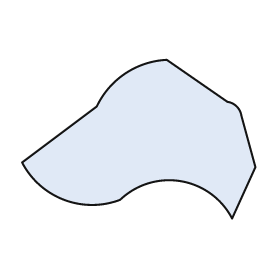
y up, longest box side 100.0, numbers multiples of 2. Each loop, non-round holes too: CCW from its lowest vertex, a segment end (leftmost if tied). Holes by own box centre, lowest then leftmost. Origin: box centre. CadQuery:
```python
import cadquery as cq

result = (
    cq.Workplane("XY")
    .moveTo(40.0, -34.0)
    .lineTo(50.0, -12.0)
    .lineTo(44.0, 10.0)
    .threePointArc((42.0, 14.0), (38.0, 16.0))
    .lineTo(12.0, 34.0)
    .threePointArc((-6.0, 28.0), (-18.0, 14.0))
    .lineTo(-50.0, -10.0)
    .threePointArc((-32.0, -26.0), (-8.0, -26.0))
    .threePointArc((18.0, -18.0), (40.0, -34.0))
    .close()
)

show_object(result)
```